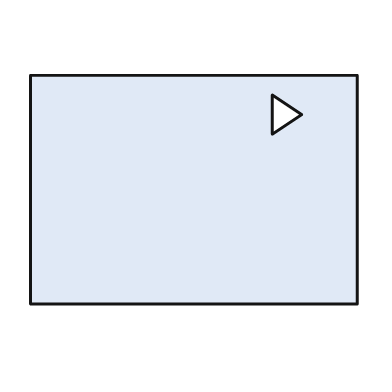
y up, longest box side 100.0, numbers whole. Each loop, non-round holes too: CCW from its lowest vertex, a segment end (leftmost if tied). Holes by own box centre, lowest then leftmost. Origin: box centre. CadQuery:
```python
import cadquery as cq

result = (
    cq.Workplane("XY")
    .moveTo(-50.0, -35.0)
    .lineTo(50.0, -35.0)
    .lineTo(50.0, 35.0)
    .lineTo(-50.0, 35.0)
    .close()
    .moveTo(24.0, 17.0)
    .lineTo(33.0, 23.0)
    .lineTo(24.0, 29.0)
    .close()
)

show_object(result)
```